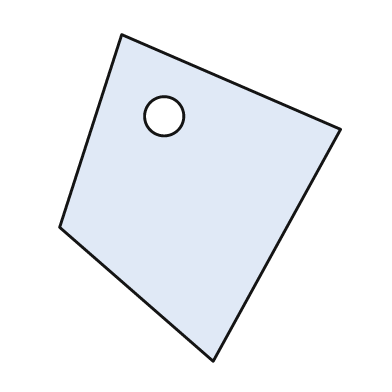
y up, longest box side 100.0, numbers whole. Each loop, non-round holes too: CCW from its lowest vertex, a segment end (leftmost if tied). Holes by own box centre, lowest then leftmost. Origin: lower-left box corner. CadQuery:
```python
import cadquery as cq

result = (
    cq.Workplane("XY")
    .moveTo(47.0, 0.0)
    .lineTo(86.0, 71.0)
    .lineTo(19.0, 100.0)
    .lineTo(0.0, 41.0)
    .close()
    .moveTo(32.0, 75.0)
    .circle(6.0)
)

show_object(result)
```